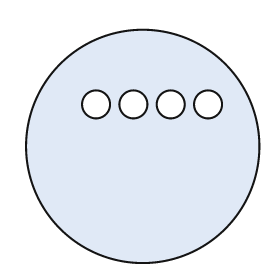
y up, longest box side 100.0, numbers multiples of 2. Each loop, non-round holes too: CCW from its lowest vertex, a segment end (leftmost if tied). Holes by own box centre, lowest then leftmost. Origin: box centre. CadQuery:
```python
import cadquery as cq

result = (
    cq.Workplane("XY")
    .moveTo(0.0, 0.0)
    .circle(50.0)
    .moveTo(-20.0, 18.0)
    .circle(6.0)
    .moveTo(-4.0, 18.0)
    .circle(6.0)
    .moveTo(12.0, 18.0)
    .circle(6.0)
    .moveTo(28.0, 18.0)
    .circle(6.0)
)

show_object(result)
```